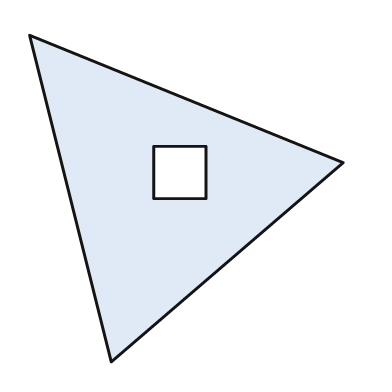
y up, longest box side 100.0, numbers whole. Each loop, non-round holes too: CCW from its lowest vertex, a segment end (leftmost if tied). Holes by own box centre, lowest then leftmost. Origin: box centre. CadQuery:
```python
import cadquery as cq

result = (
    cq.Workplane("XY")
    .moveTo(-23.0, -50.0)
    .lineTo(48.0, 11.0)
    .lineTo(-48.0, 50.0)
    .close()
    .moveTo(-10.0, 0.0)
    .lineTo(6.0, 0.0)
    .lineTo(6.0, 16.0)
    .lineTo(-10.0, 16.0)
    .close()
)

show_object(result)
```